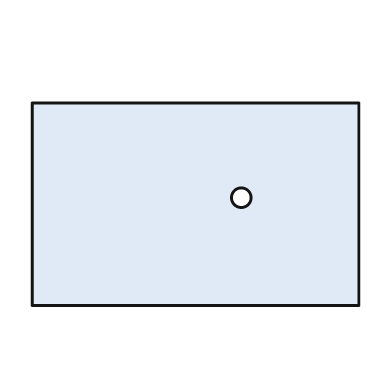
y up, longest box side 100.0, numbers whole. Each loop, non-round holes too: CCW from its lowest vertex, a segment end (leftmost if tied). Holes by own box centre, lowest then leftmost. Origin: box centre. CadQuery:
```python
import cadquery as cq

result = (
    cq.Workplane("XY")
    .moveTo(-50.0, -31.0)
    .lineTo(50.0, -31.0)
    .lineTo(50.0, 31.0)
    .lineTo(-50.0, 31.0)
    .close()
    .moveTo(14.0, 2.0)
    .circle(3.0)
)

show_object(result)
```